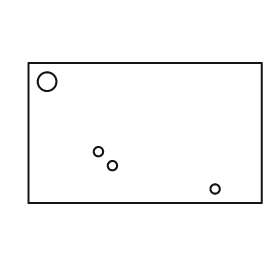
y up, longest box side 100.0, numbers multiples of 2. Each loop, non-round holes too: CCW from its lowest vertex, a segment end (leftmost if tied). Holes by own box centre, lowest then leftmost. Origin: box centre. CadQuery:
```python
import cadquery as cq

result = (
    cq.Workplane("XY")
    .moveTo(-50.0, -30.0)
    .lineTo(50.0, -30.0)
    .lineTo(50.0, 30.0)
    .lineTo(-50.0, 30.0)
    .close()
    .moveTo(30.0, -24.0)
    .circle(2.0)
    .moveTo(-14.0, -14.0)
    .circle(2.0)
    .moveTo(-20.0, -8.0)
    .circle(2.0)
    .moveTo(-42.0, 22.0)
    .circle(4.0)
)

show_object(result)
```